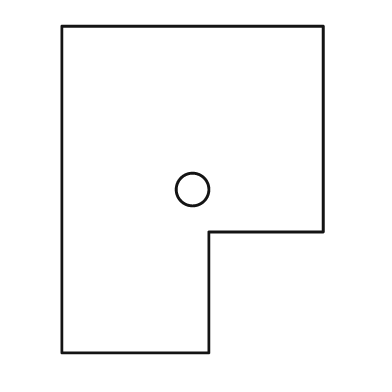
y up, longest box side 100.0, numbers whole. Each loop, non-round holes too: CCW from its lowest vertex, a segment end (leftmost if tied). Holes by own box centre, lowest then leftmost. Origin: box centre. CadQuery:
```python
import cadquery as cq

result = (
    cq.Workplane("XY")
    .moveTo(-40.0, -50.0)
    .lineTo(5.0, -50.0)
    .lineTo(5.0, -13.0)
    .lineTo(40.0, -13.0)
    .lineTo(40.0, 50.0)
    .lineTo(-40.0, 50.0)
    .close()
    .moveTo(0.0, 0.0)
    .circle(5.0)
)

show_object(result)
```